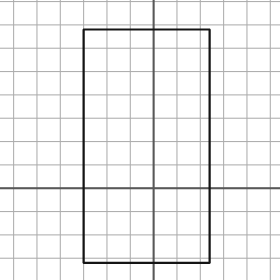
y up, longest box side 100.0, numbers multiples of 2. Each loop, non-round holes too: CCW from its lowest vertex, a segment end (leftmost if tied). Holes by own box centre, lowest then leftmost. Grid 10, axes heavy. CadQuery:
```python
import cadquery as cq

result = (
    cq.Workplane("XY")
    .moveTo(-30.0, -32.0)
    .lineTo(24.0, -32.0)
    .lineTo(24.0, 68.0)
    .lineTo(-30.0, 68.0)
    .close()
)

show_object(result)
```